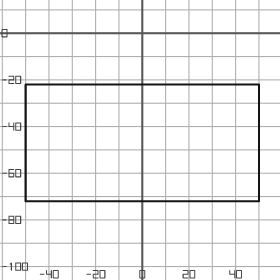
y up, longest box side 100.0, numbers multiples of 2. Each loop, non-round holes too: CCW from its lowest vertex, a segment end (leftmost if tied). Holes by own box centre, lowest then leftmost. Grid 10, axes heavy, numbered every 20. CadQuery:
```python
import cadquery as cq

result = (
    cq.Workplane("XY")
    .moveTo(-50.0, -72.0)
    .lineTo(50.0, -72.0)
    .lineTo(50.0, -22.0)
    .lineTo(-50.0, -22.0)
    .close()
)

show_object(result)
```